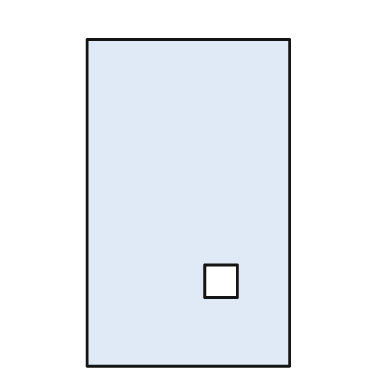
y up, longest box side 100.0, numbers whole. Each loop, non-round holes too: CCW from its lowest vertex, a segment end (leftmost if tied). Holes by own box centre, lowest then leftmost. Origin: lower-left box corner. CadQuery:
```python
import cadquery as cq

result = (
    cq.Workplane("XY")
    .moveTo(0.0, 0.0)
    .lineTo(62.0, 0.0)
    .lineTo(62.0, 100.0)
    .lineTo(0.0, 100.0)
    .close()
    .moveTo(36.0, 21.0)
    .lineTo(46.0, 21.0)
    .lineTo(46.0, 31.0)
    .lineTo(36.0, 31.0)
    .close()
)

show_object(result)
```